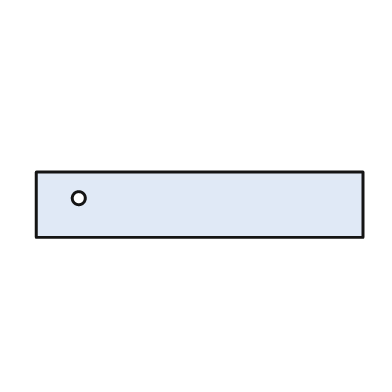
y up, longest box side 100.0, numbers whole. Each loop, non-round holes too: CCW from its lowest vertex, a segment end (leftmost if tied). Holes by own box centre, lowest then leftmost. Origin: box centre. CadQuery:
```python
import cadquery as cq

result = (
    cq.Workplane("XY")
    .moveTo(-50.0, -10.0)
    .lineTo(50.0, -10.0)
    .lineTo(50.0, 10.0)
    .lineTo(-50.0, 10.0)
    .close()
    .moveTo(-37.0, 2.0)
    .circle(2.0)
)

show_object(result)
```